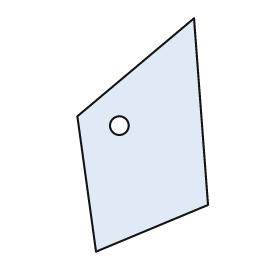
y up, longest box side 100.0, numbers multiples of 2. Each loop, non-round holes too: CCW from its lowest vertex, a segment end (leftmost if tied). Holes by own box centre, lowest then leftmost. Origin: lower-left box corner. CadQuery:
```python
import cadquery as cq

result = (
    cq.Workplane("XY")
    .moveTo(8.0, 0.0)
    .lineTo(56.0, 20.0)
    .lineTo(50.0, 100.0)
    .lineTo(0.0, 58.0)
    .close()
    .moveTo(18.0, 54.0)
    .circle(4.0)
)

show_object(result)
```